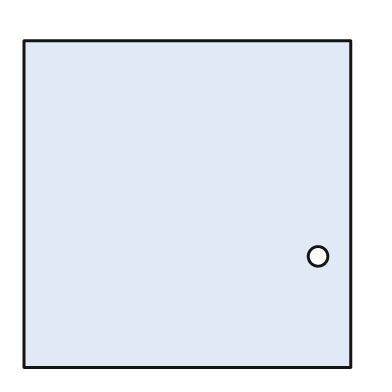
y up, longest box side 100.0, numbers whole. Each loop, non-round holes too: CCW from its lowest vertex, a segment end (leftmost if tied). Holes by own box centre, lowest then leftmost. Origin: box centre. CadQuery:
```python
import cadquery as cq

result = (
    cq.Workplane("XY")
    .moveTo(-50.0, -50.0)
    .lineTo(50.0, -50.0)
    .lineTo(50.0, 50.0)
    .lineTo(-50.0, 50.0)
    .close()
    .moveTo(40.0, -16.0)
    .circle(3.0)
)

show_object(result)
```